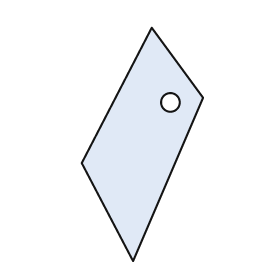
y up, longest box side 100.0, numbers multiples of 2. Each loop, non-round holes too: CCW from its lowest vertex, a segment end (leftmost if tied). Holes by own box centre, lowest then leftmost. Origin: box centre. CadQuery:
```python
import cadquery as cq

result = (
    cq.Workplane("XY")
    .moveTo(-4.0, -50.0)
    .lineTo(26.0, 20.0)
    .lineTo(4.0, 50.0)
    .lineTo(-26.0, -8.0)
    .close()
    .moveTo(12.0, 18.0)
    .circle(4.0)
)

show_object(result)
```